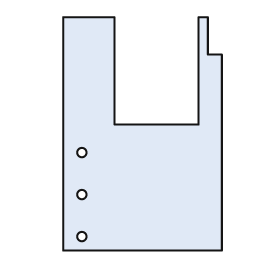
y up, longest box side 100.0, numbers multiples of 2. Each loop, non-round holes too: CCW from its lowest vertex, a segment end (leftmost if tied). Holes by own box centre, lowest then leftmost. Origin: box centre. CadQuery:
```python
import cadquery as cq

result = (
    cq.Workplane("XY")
    .moveTo(-34.0, -50.0)
    .lineTo(34.0, -50.0)
    .lineTo(34.0, 34.0)
    .lineTo(28.0, 34.0)
    .lineTo(28.0, 50.0)
    .lineTo(24.0, 50.0)
    .lineTo(24.0, 4.0)
    .lineTo(-12.0, 4.0)
    .lineTo(-12.0, 50.0)
    .lineTo(-34.0, 50.0)
    .close()
    .moveTo(-26.0, -44.0)
    .circle(2.0)
    .moveTo(-26.0, -26.0)
    .circle(2.0)
    .moveTo(-26.0, -8.0)
    .circle(2.0)
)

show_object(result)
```